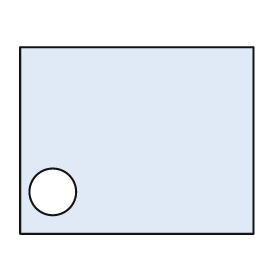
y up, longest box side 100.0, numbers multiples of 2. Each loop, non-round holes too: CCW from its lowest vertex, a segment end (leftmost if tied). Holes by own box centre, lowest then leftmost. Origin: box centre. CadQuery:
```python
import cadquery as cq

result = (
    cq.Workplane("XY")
    .moveTo(-50.0, -40.0)
    .lineTo(50.0, -40.0)
    .lineTo(50.0, 40.0)
    .lineTo(-50.0, 40.0)
    .close()
    .moveTo(-36.0, -22.0)
    .circle(10.0)
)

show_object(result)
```